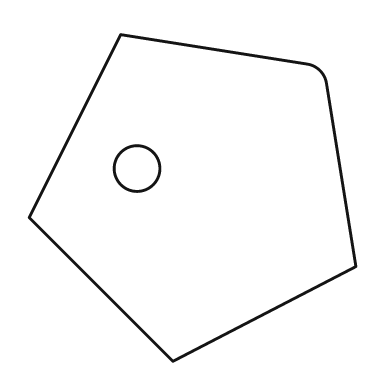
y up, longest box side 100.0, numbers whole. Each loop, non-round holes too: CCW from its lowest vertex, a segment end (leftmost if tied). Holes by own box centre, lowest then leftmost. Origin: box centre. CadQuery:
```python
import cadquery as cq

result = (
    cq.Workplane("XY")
    .moveTo(-6.0, -50.0)
    .lineTo(50.0, -21.0)
    .lineTo(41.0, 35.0)
    .threePointArc((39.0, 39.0), (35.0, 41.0))
    .lineTo(-22.0, 50.0)
    .lineTo(-50.0, -6.0)
    .close()
    .moveTo(-17.0, 9.0)
    .circle(7.0)
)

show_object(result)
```